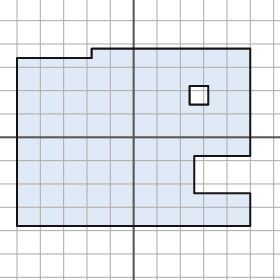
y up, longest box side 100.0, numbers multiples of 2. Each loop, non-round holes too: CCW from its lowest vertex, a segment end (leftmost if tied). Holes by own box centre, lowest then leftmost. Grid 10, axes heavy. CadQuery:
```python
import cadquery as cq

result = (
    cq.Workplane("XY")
    .moveTo(-50.0, -38.0)
    .lineTo(50.0, -38.0)
    .lineTo(50.0, -24.0)
    .lineTo(26.0, -24.0)
    .lineTo(26.0, -8.0)
    .lineTo(50.0, -8.0)
    .lineTo(50.0, 38.0)
    .lineTo(-18.0, 38.0)
    .lineTo(-18.0, 34.0)
    .lineTo(-50.0, 34.0)
    .close()
    .moveTo(24.0, 14.0)
    .lineTo(32.0, 14.0)
    .lineTo(32.0, 22.0)
    .lineTo(24.0, 22.0)
    .close()
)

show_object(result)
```